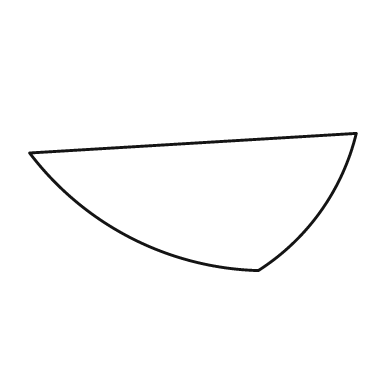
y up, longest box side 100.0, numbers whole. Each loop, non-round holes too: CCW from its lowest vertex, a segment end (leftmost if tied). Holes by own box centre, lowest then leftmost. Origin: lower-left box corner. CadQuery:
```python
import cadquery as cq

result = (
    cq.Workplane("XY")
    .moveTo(70.0, 0.0)
    .threePointArc((89.0, 18.0), (100.0, 42.0))
    .lineTo(0.0, 36.0)
    .threePointArc((31.0, 10.0), (70.0, 0.0))
    .close()
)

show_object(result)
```